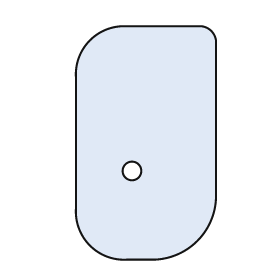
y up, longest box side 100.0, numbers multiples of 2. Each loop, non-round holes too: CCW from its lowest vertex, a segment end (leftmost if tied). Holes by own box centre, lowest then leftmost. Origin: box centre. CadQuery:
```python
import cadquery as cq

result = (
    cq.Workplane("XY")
    .moveTo(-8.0, -50.0)
    .lineTo(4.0, -50.0)
    .threePointArc((22.0, -42.0), (30.0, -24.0))
    .lineTo(30.0, 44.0)
    .threePointArc((28.0, 48.0), (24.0, 50.0))
    .lineTo(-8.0, 50.0)
    .threePointArc((-24.0, 44.0), (-30.0, 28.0))
    .lineTo(-30.0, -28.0)
    .threePointArc((-24.0, -44.0), (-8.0, -50.0))
    .close()
    .moveTo(-6.0, -12.0)
    .circle(4.0)
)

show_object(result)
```